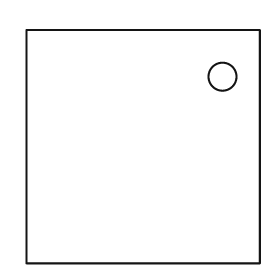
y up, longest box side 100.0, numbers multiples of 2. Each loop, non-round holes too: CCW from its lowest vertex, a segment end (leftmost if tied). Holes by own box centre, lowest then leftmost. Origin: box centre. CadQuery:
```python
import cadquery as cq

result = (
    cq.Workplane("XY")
    .moveTo(-50.0, -50.0)
    .lineTo(50.0, -50.0)
    .lineTo(50.0, 50.0)
    .lineTo(-50.0, 50.0)
    .close()
    .moveTo(34.0, 30.0)
    .circle(6.0)
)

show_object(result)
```